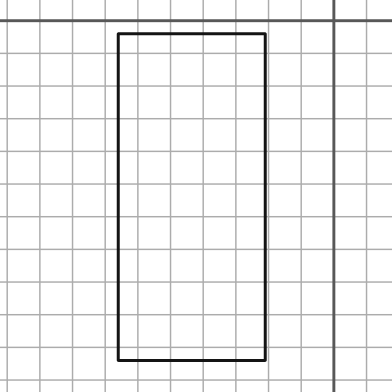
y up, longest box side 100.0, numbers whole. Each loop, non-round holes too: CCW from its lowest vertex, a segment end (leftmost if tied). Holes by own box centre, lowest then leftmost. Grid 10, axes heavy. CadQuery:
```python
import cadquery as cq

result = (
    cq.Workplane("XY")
    .moveTo(-66.0, -104.0)
    .lineTo(-21.0, -104.0)
    .lineTo(-21.0, -4.0)
    .lineTo(-66.0, -4.0)
    .close()
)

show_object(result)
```